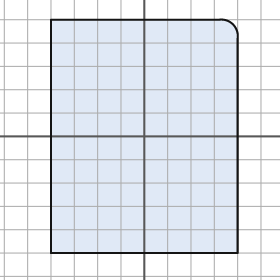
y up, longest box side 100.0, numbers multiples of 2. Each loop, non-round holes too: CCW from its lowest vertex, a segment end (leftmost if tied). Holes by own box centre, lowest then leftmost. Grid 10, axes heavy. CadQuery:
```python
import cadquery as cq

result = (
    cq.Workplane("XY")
    .moveTo(-40.0, -50.0)
    .lineTo(40.0, -50.0)
    .lineTo(40.0, 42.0)
    .threePointArc((38.0, 48.0), (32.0, 50.0))
    .lineTo(-40.0, 50.0)
    .close()
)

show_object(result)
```